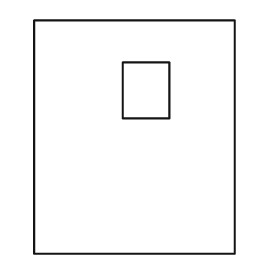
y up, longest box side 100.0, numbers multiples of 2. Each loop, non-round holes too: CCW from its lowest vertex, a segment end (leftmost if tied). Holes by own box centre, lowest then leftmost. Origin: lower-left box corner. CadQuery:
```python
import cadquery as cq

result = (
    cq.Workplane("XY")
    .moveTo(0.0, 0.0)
    .lineTo(86.0, 0.0)
    .lineTo(86.0, 100.0)
    .lineTo(0.0, 100.0)
    .close()
    .moveTo(38.0, 58.0)
    .lineTo(58.0, 58.0)
    .lineTo(58.0, 82.0)
    .lineTo(38.0, 82.0)
    .close()
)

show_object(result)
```